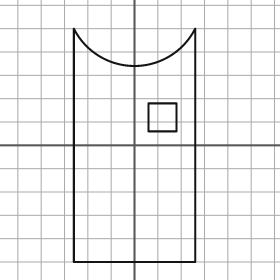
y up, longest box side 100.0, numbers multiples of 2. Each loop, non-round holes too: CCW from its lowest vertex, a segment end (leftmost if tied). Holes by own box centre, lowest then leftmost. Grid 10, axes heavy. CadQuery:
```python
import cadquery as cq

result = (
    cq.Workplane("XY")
    .moveTo(-26.0, -50.0)
    .lineTo(26.0, -50.0)
    .lineTo(26.0, 50.0)
    .threePointArc((0.0, 34.0), (-26.0, 50.0))
    .close()
    .moveTo(6.0, 6.0)
    .lineTo(18.0, 6.0)
    .lineTo(18.0, 18.0)
    .lineTo(6.0, 18.0)
    .close()
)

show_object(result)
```